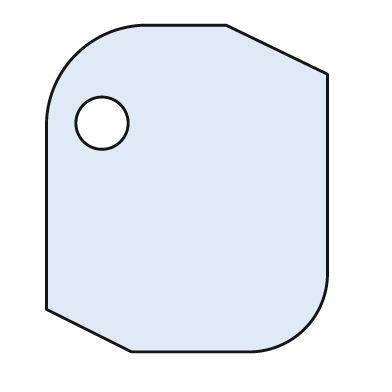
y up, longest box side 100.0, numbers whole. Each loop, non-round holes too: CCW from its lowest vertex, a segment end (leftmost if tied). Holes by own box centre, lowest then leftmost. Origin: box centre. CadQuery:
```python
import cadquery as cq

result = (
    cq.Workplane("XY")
    .moveTo(-17.0, -50.0)
    .lineTo(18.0, -50.0)
    .threePointArc((36.0, -43.0), (43.0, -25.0))
    .lineTo(43.0, 35.0)
    .lineTo(12.0, 50.0)
    .lineTo(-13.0, 50.0)
    .threePointArc((-34.0, 41.0), (-43.0, 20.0))
    .lineTo(-43.0, -37.0)
    .close()
    .moveTo(-26.0, 20.0)
    .circle(8.0)
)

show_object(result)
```